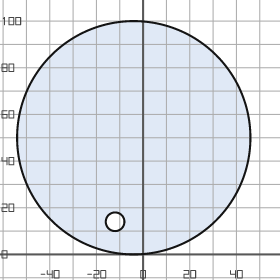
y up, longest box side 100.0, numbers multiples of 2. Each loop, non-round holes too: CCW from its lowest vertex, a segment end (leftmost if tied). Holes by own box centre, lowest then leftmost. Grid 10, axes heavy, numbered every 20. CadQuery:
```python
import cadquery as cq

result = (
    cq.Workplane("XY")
    .moveTo(-4.0, 50.0)
    .circle(50.0)
    .moveTo(-12.0, 14.0)
    .circle(4.0)
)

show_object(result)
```